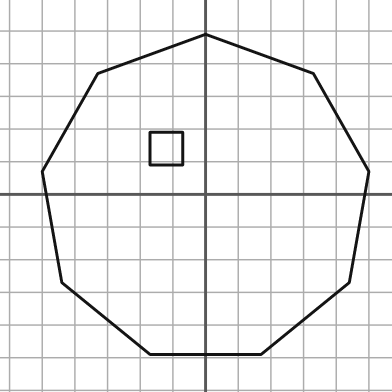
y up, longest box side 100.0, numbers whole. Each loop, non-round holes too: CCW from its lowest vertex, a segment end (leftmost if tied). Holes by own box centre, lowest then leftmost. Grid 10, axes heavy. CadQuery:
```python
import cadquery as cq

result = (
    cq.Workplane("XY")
    .moveTo(-17.0, -49.0)
    .lineTo(17.0, -49.0)
    .lineTo(44.0, -27.0)
    .lineTo(50.0, 7.0)
    .lineTo(33.0, 37.0)
    .lineTo(0.0, 49.0)
    .lineTo(-33.0, 37.0)
    .lineTo(-50.0, 7.0)
    .lineTo(-44.0, -27.0)
    .close()
    .moveTo(-17.0, 9.0)
    .lineTo(-7.0, 9.0)
    .lineTo(-7.0, 19.0)
    .lineTo(-17.0, 19.0)
    .close()
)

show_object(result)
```